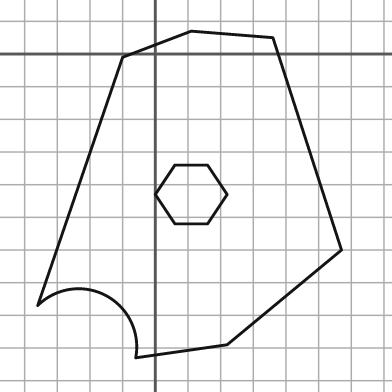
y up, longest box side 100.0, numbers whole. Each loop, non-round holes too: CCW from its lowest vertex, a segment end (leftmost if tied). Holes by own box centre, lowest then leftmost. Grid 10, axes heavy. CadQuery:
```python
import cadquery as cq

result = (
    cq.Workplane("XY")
    .moveTo(-6.0, -93.0)
    .lineTo(22.0, -89.0)
    .lineTo(57.0, -60.0)
    .lineTo(36.0, 5.0)
    .lineTo(11.0, 7.0)
    .lineTo(-10.0, -1.0)
    .lineTo(-36.0, -77.0)
    .threePointArc((-15.0, -74.0), (-6.0, -93.0))
    .close()
    .moveTo(6.0, -52.0)
    .lineTo(16.0, -52.0)
    .lineTo(22.0, -43.0)
    .lineTo(16.0, -34.0)
    .lineTo(6.0, -34.0)
    .lineTo(0.0, -43.0)
    .close()
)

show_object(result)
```